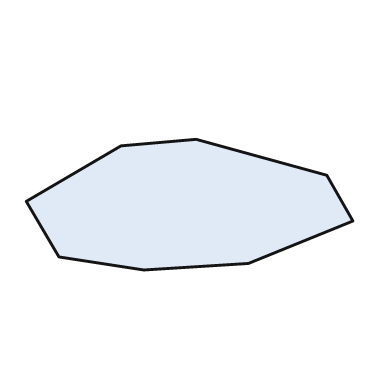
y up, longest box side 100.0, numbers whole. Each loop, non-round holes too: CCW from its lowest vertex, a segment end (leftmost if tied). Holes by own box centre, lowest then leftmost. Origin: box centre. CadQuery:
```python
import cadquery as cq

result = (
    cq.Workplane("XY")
    .moveTo(-14.0, -20.0)
    .lineTo(18.0, -18.0)
    .lineTo(50.0, -5.0)
    .lineTo(42.0, 9.0)
    .lineTo(2.0, 20.0)
    .lineTo(-21.0, 18.0)
    .lineTo(-50.0, 1.0)
    .lineTo(-40.0, -16.0)
    .close()
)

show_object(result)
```